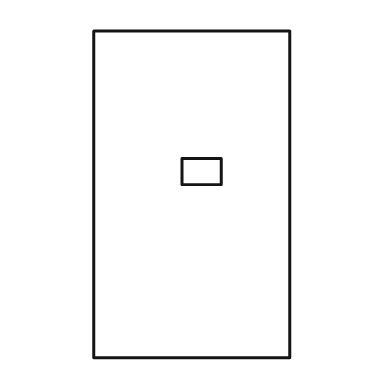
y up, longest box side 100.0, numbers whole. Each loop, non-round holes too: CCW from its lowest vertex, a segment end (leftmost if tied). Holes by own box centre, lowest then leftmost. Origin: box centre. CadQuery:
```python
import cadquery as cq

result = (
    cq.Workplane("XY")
    .moveTo(-30.0, -50.0)
    .lineTo(30.0, -50.0)
    .lineTo(30.0, 50.0)
    .lineTo(-30.0, 50.0)
    .close()
    .moveTo(-3.0, 3.0)
    .lineTo(9.0, 3.0)
    .lineTo(9.0, 11.0)
    .lineTo(-3.0, 11.0)
    .close()
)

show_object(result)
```